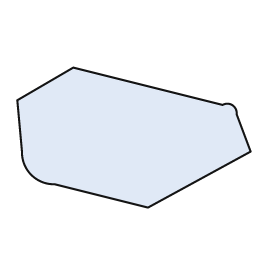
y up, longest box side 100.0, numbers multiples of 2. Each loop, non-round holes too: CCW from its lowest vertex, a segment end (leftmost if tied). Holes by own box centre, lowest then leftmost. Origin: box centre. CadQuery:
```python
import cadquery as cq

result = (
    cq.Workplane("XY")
    .moveTo(6.0, -30.0)
    .lineTo(50.0, -6.0)
    .lineTo(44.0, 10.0)
    .threePointArc((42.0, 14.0), (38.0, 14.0))
    .lineTo(-26.0, 30.0)
    .lineTo(-50.0, 16.0)
    .lineTo(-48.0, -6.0)
    .threePointArc((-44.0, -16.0), (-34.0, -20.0))
    .close()
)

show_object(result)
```